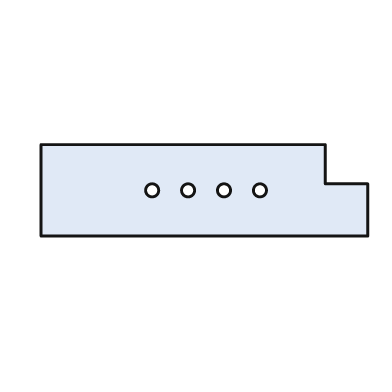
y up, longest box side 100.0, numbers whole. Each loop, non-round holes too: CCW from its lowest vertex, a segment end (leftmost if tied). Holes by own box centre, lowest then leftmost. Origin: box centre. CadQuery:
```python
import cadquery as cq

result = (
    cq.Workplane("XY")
    .moveTo(-50.0, -14.0)
    .lineTo(50.0, -14.0)
    .lineTo(50.0, 2.0)
    .lineTo(37.0, 2.0)
    .lineTo(37.0, 14.0)
    .lineTo(-50.0, 14.0)
    .close()
    .moveTo(-16.0, 0.0)
    .circle(2.0)
    .moveTo(-5.0, 0.0)
    .circle(2.0)
    .moveTo(6.0, 0.0)
    .circle(2.0)
    .moveTo(17.0, 0.0)
    .circle(2.0)
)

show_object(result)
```